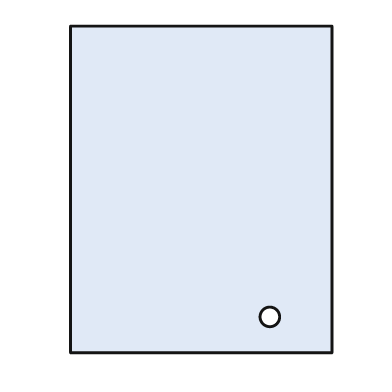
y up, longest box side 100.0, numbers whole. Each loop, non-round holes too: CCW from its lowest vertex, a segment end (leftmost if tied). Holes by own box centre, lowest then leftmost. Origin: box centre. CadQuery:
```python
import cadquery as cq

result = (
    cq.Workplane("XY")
    .moveTo(-40.0, -50.0)
    .lineTo(40.0, -50.0)
    .lineTo(40.0, 50.0)
    .lineTo(-40.0, 50.0)
    .close()
    .moveTo(21.0, -39.0)
    .circle(3.0)
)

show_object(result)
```